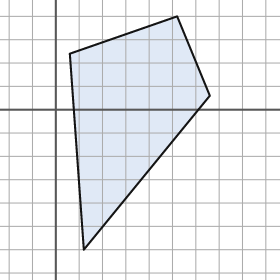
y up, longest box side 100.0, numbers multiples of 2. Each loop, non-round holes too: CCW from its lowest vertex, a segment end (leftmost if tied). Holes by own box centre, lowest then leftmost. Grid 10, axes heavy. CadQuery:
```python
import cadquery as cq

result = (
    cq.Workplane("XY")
    .moveTo(12.0, -60.0)
    .lineTo(66.0, 6.0)
    .lineTo(52.0, 40.0)
    .lineTo(6.0, 24.0)
    .close()
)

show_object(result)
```